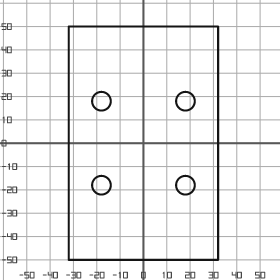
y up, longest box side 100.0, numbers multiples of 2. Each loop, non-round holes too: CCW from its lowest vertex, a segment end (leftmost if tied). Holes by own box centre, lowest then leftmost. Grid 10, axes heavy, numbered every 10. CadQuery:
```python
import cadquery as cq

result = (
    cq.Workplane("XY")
    .moveTo(-32.0, -50.0)
    .lineTo(32.0, -50.0)
    .lineTo(32.0, 50.0)
    .lineTo(-32.0, 50.0)
    .close()
    .moveTo(-18.0, -18.0)
    .circle(4.0)
    .moveTo(18.0, -18.0)
    .circle(4.0)
    .moveTo(-18.0, 18.0)
    .circle(4.0)
    .moveTo(18.0, 18.0)
    .circle(4.0)
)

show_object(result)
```